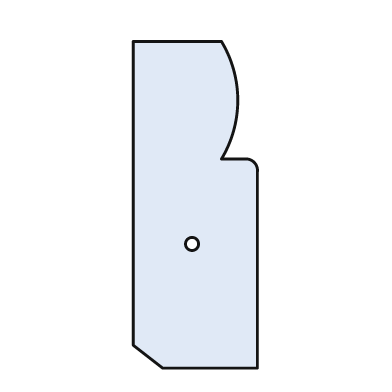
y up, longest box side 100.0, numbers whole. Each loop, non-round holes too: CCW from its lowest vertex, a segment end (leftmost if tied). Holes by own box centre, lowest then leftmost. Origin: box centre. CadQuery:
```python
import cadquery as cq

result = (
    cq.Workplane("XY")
    .moveTo(-10.0, -50.0)
    .lineTo(19.0, -50.0)
    .lineTo(19.0, 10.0)
    .threePointArc((18.0, 13.0), (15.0, 14.0))
    .lineTo(8.0, 14.0)
    .threePointArc((13.0, 32.0), (8.0, 50.0))
    .lineTo(-19.0, 50.0)
    .lineTo(-19.0, -43.0)
    .close()
    .moveTo(-1.0, -12.0)
    .circle(2.0)
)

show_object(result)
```